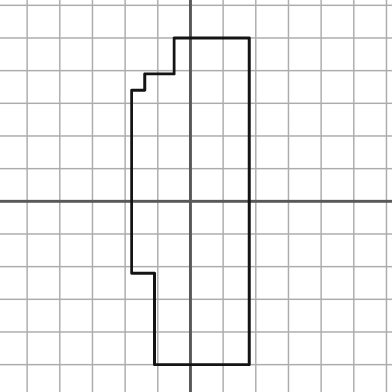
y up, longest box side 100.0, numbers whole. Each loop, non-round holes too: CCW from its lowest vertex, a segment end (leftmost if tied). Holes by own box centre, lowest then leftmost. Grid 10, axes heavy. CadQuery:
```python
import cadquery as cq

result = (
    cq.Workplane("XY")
    .moveTo(-11.0, -50.0)
    .lineTo(18.0, -50.0)
    .lineTo(18.0, 50.0)
    .lineTo(-5.0, 50.0)
    .lineTo(-5.0, 39.0)
    .lineTo(-14.0, 39.0)
    .lineTo(-14.0, 34.0)
    .lineTo(-18.0, 34.0)
    .lineTo(-18.0, -22.0)
    .lineTo(-11.0, -22.0)
    .close()
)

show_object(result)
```